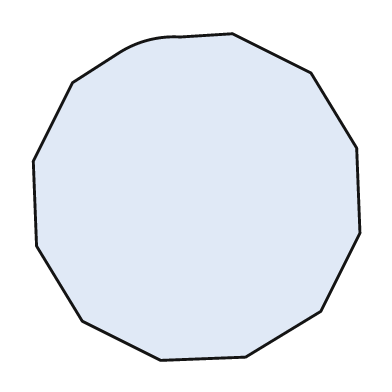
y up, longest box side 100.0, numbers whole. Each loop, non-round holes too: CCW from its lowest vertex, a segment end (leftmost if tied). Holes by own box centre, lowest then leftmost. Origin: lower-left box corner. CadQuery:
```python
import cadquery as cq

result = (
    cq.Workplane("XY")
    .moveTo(39.0, 0.0)
    .lineTo(65.0, 1.0)
    .lineTo(88.0, 15.0)
    .lineTo(100.0, 39.0)
    .lineTo(99.0, 65.0)
    .lineTo(85.0, 88.0)
    .lineTo(61.0, 100.0)
    .lineTo(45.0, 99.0)
    .threePointArc((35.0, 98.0), (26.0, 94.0))
    .lineTo(12.0, 85.0)
    .lineTo(0.0, 61.0)
    .lineTo(1.0, 35.0)
    .lineTo(15.0, 12.0)
    .close()
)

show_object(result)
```